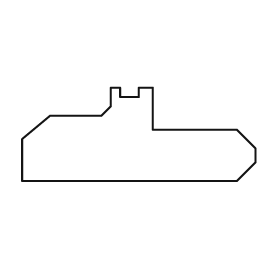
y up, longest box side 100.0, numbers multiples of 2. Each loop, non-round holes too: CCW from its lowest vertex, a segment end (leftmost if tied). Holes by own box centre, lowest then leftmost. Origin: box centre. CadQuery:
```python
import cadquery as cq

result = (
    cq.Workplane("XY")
    .moveTo(-50.0, -20.0)
    .lineTo(42.0, -20.0)
    .lineTo(50.0, -12.0)
    .lineTo(50.0, -6.0)
    .lineTo(42.0, 2.0)
    .lineTo(6.0, 2.0)
    .lineTo(6.0, 20.0)
    .lineTo(0.0, 20.0)
    .lineTo(0.0, 16.0)
    .lineTo(-8.0, 16.0)
    .lineTo(-8.0, 20.0)
    .lineTo(-12.0, 20.0)
    .lineTo(-12.0, 12.0)
    .lineTo(-16.0, 8.0)
    .lineTo(-38.0, 8.0)
    .lineTo(-50.0, -2.0)
    .close()
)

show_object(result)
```